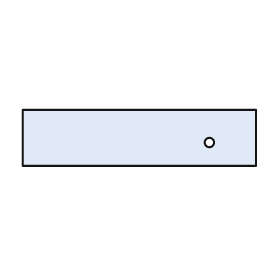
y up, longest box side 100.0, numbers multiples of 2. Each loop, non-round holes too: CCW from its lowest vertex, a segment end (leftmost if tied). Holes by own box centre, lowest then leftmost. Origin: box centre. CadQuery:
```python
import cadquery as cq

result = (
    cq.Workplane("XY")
    .moveTo(-50.0, -12.0)
    .lineTo(50.0, -12.0)
    .lineTo(50.0, 12.0)
    .lineTo(-50.0, 12.0)
    .close()
    .moveTo(30.0, -2.0)
    .circle(2.0)
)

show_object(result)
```